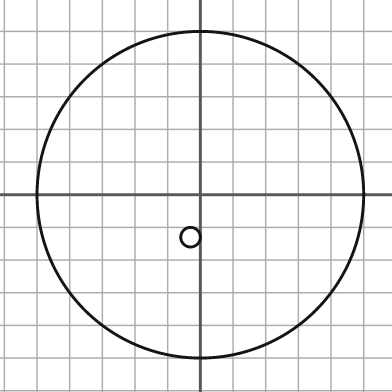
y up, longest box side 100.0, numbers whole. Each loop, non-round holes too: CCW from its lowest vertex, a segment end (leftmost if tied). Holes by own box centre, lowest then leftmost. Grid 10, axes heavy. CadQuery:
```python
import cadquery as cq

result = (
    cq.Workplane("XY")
    .moveTo(0.0, 0.0)
    .circle(50.0)
    .moveTo(-3.0, -13.0)
    .circle(3.0)
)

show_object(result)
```